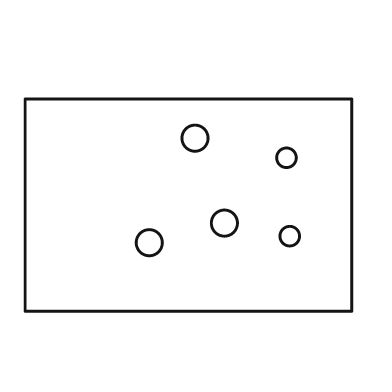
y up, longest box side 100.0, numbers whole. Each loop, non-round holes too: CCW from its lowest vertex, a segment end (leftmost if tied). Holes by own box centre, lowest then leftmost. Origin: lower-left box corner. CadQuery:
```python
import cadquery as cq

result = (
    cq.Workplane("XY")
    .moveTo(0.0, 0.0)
    .lineTo(100.0, 0.0)
    .lineTo(100.0, 65.0)
    .lineTo(0.0, 65.0)
    .close()
    .moveTo(38.0, 21.0)
    .circle(4.0)
    .moveTo(81.0, 23.0)
    .circle(3.0)
    .moveTo(61.0, 27.0)
    .circle(4.0)
    .moveTo(80.0, 47.0)
    .circle(3.0)
    .moveTo(52.0, 53.0)
    .circle(4.0)
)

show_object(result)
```